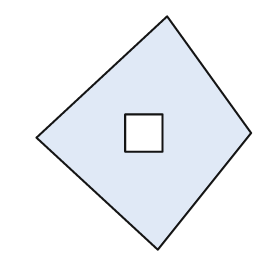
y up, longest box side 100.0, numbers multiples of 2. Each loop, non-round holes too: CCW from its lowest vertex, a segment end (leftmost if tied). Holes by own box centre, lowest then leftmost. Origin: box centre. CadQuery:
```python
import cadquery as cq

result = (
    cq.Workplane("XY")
    .moveTo(6.0, -50.0)
    .lineTo(46.0, 0.0)
    .lineTo(10.0, 50.0)
    .lineTo(-46.0, -2.0)
    .close()
    .moveTo(-8.0, -8.0)
    .lineTo(8.0, -8.0)
    .lineTo(8.0, 8.0)
    .lineTo(-8.0, 8.0)
    .close()
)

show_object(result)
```